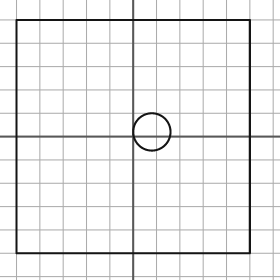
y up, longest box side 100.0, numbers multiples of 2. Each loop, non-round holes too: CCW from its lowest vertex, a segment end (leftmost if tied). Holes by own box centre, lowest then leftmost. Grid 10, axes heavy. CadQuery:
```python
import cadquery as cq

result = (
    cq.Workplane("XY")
    .moveTo(-50.0, -50.0)
    .lineTo(50.0, -50.0)
    .lineTo(50.0, 50.0)
    .lineTo(-50.0, 50.0)
    .close()
    .moveTo(8.0, 2.0)
    .circle(8.0)
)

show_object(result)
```